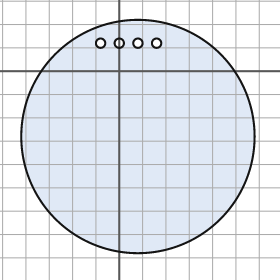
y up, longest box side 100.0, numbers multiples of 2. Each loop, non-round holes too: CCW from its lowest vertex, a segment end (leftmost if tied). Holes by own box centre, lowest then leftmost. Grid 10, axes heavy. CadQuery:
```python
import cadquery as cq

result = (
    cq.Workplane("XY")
    .moveTo(8.0, -28.0)
    .circle(50.0)
    .moveTo(-8.0, 12.0)
    .circle(2.0)
    .moveTo(0.0, 12.0)
    .circle(2.0)
    .moveTo(8.0, 12.0)
    .circle(2.0)
    .moveTo(16.0, 12.0)
    .circle(2.0)
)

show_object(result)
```